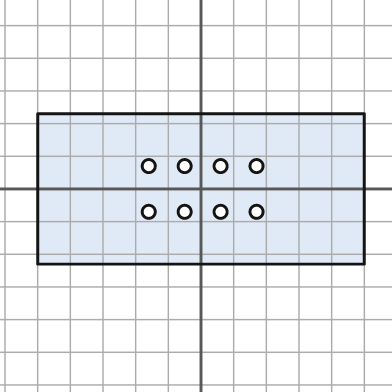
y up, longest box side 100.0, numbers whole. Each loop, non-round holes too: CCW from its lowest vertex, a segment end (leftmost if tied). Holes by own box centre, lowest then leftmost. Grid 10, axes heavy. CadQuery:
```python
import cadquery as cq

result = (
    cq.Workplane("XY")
    .moveTo(-50.0, -23.0)
    .lineTo(50.0, -23.0)
    .lineTo(50.0, 23.0)
    .lineTo(-50.0, 23.0)
    .close()
    .moveTo(-16.0, -7.0)
    .circle(2.0)
    .moveTo(-5.0, -7.0)
    .circle(2.0)
    .moveTo(6.0, -7.0)
    .circle(2.0)
    .moveTo(17.0, -7.0)
    .circle(2.0)
    .moveTo(-16.0, 7.0)
    .circle(2.0)
    .moveTo(-5.0, 7.0)
    .circle(2.0)
    .moveTo(6.0, 7.0)
    .circle(2.0)
    .moveTo(17.0, 7.0)
    .circle(2.0)
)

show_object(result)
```